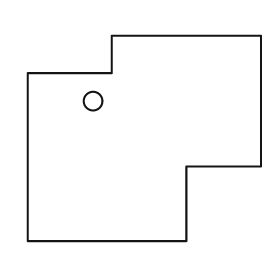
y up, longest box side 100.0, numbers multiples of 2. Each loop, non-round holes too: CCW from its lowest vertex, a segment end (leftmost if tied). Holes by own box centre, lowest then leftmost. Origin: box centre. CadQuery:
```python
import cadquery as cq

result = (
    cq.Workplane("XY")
    .moveTo(-50.0, -44.0)
    .lineTo(18.0, -44.0)
    .lineTo(18.0, -12.0)
    .lineTo(50.0, -12.0)
    .lineTo(50.0, 44.0)
    .lineTo(-14.0, 44.0)
    .lineTo(-14.0, 28.0)
    .lineTo(-50.0, 28.0)
    .close()
    .moveTo(-22.0, 16.0)
    .circle(4.0)
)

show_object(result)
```